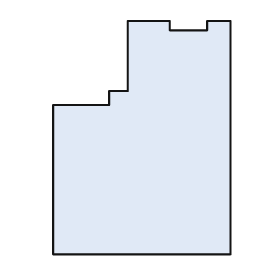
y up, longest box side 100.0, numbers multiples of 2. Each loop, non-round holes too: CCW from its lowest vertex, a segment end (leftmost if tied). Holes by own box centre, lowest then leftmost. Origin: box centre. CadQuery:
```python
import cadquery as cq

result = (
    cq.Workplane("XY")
    .moveTo(-38.0, -50.0)
    .lineTo(38.0, -50.0)
    .lineTo(38.0, 50.0)
    .lineTo(28.0, 50.0)
    .lineTo(28.0, 46.0)
    .lineTo(12.0, 46.0)
    .lineTo(12.0, 50.0)
    .lineTo(-6.0, 50.0)
    .lineTo(-6.0, 20.0)
    .lineTo(-14.0, 20.0)
    .lineTo(-14.0, 14.0)
    .lineTo(-38.0, 14.0)
    .close()
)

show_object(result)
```